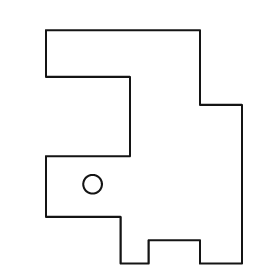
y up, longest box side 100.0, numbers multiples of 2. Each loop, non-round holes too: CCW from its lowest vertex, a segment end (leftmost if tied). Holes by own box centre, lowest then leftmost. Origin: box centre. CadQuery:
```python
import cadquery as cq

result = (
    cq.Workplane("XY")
    .moveTo(-10.0, -50.0)
    .lineTo(2.0, -50.0)
    .lineTo(2.0, -40.0)
    .lineTo(24.0, -40.0)
    .lineTo(24.0, -50.0)
    .lineTo(42.0, -50.0)
    .lineTo(42.0, 18.0)
    .lineTo(24.0, 18.0)
    .lineTo(24.0, 50.0)
    .lineTo(-42.0, 50.0)
    .lineTo(-42.0, 30.0)
    .lineTo(-6.0, 30.0)
    .lineTo(-6.0, -4.0)
    .lineTo(-42.0, -4.0)
    .lineTo(-42.0, -30.0)
    .lineTo(-10.0, -30.0)
    .close()
    .moveTo(-22.0, -16.0)
    .circle(4.0)
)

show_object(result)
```